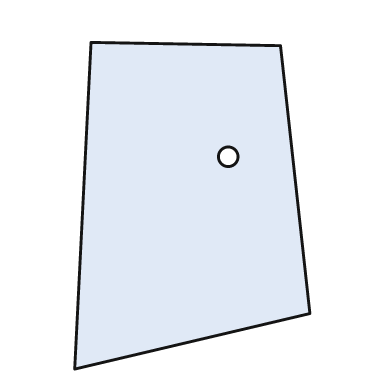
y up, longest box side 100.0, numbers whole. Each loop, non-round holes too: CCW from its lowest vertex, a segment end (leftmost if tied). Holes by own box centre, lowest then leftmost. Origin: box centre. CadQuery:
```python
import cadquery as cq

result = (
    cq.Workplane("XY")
    .moveTo(-36.0, -50.0)
    .lineTo(36.0, -33.0)
    .lineTo(27.0, 49.0)
    .lineTo(-31.0, 50.0)
    .close()
    .moveTo(11.0, 15.0)
    .circle(3.0)
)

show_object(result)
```